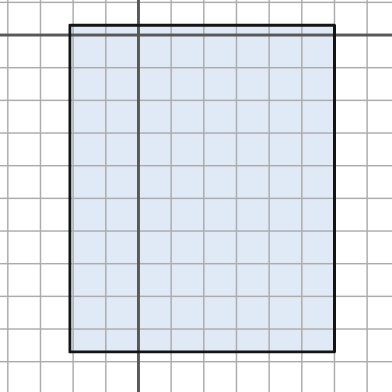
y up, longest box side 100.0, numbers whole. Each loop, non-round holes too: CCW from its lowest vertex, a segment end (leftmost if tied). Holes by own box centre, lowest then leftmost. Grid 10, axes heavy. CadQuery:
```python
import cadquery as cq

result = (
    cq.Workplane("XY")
    .moveTo(-21.0, -97.0)
    .lineTo(60.0, -97.0)
    .lineTo(60.0, 3.0)
    .lineTo(-21.0, 3.0)
    .close()
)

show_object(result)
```